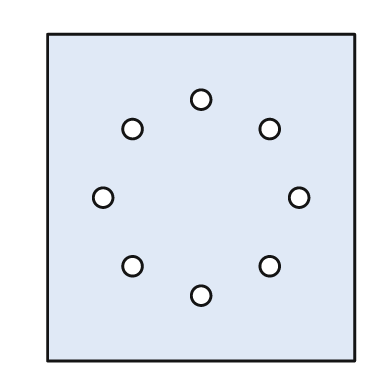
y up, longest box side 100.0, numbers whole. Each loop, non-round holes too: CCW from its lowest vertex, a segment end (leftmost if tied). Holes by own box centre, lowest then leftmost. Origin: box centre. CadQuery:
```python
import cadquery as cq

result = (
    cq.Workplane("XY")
    .moveTo(-47.0, -50.0)
    .lineTo(47.0, -50.0)
    .lineTo(47.0, 50.0)
    .lineTo(-47.0, 50.0)
    .close()
    .moveTo(0.0, -30.0)
    .circle(3.0)
    .moveTo(-21.0, -21.0)
    .circle(3.0)
    .moveTo(21.0, -21.0)
    .circle(3.0)
    .moveTo(-30.0, 0.0)
    .circle(3.0)
    .moveTo(30.0, 0.0)
    .circle(3.0)
    .moveTo(-21.0, 21.0)
    .circle(3.0)
    .moveTo(21.0, 21.0)
    .circle(3.0)
    .moveTo(0.0, 30.0)
    .circle(3.0)
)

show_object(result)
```